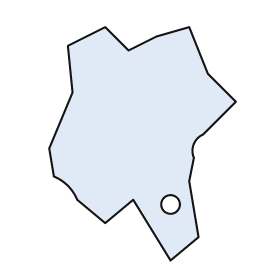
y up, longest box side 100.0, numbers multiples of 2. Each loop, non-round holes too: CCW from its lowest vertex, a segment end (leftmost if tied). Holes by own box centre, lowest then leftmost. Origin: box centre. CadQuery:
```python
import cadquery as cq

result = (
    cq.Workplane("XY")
    .moveTo(12.0, -50.0)
    .lineTo(24.0, -40.0)
    .lineTo(20.0, -16.0)
    .lineTo(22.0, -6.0)
    .threePointArc((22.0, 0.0), (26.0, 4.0))
    .lineTo(40.0, 18.0)
    .lineTo(28.0, 30.0)
    .lineTo(20.0, 50.0)
    .lineTo(6.0, 46.0)
    .lineTo(-6.0, 40.0)
    .lineTo(-16.0, 50.0)
    .lineTo(-32.0, 42.0)
    .lineTo(-30.0, 22.0)
    .lineTo(-40.0, -2.0)
    .lineTo(-38.0, -14.0)
    .threePointArc((-32.0, -18.0), (-28.0, -24.0))
    .lineTo(-16.0, -34.0)
    .lineTo(-4.0, -24.0)
    .close()
    .moveTo(12.0, -26.0)
    .circle(4.0)
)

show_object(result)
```